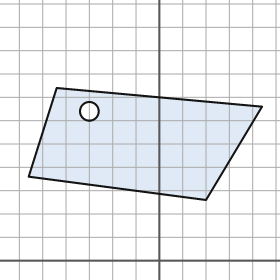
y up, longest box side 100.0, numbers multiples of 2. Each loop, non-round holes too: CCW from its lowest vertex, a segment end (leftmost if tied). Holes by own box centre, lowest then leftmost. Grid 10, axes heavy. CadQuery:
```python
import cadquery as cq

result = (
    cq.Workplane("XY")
    .moveTo(20.0, 26.0)
    .lineTo(44.0, 66.0)
    .lineTo(-44.0, 74.0)
    .lineTo(-56.0, 36.0)
    .close()
    .moveTo(-30.0, 64.0)
    .circle(4.0)
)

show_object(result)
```